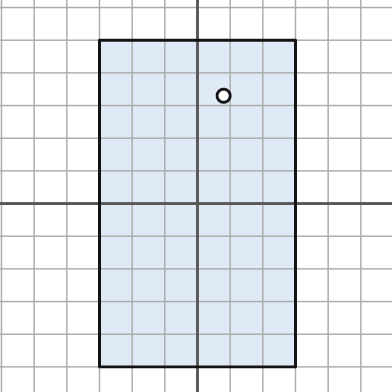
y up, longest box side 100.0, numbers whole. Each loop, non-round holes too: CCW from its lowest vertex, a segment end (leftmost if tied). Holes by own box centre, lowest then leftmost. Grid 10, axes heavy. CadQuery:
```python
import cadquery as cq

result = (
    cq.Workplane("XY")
    .moveTo(-30.0, -50.0)
    .lineTo(30.0, -50.0)
    .lineTo(30.0, 50.0)
    .lineTo(-30.0, 50.0)
    .close()
    .moveTo(8.0, 33.0)
    .circle(2.0)
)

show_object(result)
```